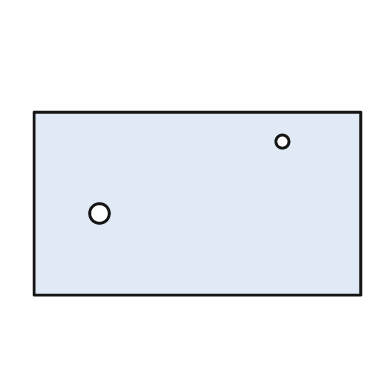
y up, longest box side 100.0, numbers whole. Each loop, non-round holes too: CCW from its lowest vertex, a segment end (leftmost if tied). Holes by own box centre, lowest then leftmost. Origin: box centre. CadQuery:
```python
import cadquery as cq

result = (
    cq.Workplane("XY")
    .moveTo(-50.0, -28.0)
    .lineTo(50.0, -28.0)
    .lineTo(50.0, 28.0)
    .lineTo(-50.0, 28.0)
    .close()
    .moveTo(-30.0, -3.0)
    .circle(3.0)
    .moveTo(26.0, 19.0)
    .circle(2.0)
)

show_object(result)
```